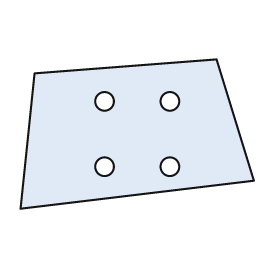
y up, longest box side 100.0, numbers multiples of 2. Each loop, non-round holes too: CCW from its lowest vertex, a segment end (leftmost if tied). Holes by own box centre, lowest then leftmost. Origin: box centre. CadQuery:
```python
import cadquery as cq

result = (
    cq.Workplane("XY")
    .moveTo(-50.0, -32.0)
    .lineTo(50.0, -20.0)
    .lineTo(34.0, 32.0)
    .lineTo(-44.0, 26.0)
    .close()
    .moveTo(-14.0, -14.0)
    .circle(4.0)
    .moveTo(14.0, -14.0)
    .circle(4.0)
    .moveTo(-14.0, 14.0)
    .circle(4.0)
    .moveTo(14.0, 14.0)
    .circle(4.0)
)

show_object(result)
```